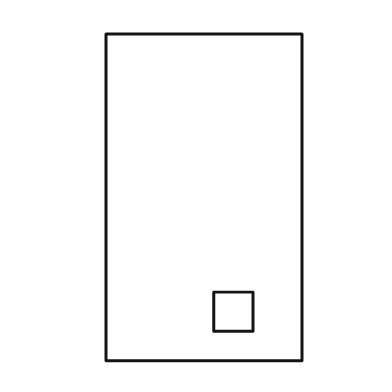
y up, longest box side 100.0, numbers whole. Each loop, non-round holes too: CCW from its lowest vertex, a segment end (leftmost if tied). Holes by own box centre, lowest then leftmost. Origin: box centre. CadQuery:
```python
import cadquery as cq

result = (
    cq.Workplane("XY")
    .moveTo(-30.0, -50.0)
    .lineTo(30.0, -50.0)
    .lineTo(30.0, 50.0)
    .lineTo(-30.0, 50.0)
    .close()
    .moveTo(3.0, -41.0)
    .lineTo(15.0, -41.0)
    .lineTo(15.0, -29.0)
    .lineTo(3.0, -29.0)
    .close()
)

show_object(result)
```